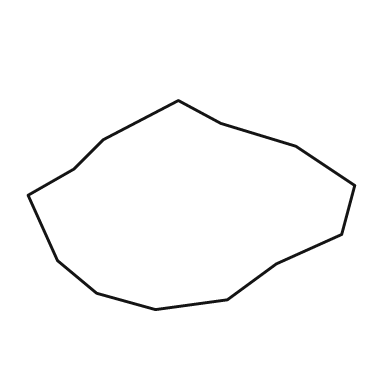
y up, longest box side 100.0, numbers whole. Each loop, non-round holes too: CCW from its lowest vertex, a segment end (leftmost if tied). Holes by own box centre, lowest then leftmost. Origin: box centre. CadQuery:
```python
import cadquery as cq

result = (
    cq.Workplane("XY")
    .moveTo(-11.0, -32.0)
    .lineTo(11.0, -29.0)
    .lineTo(26.0, -18.0)
    .lineTo(46.0, -9.0)
    .lineTo(50.0, 6.0)
    .lineTo(32.0, 18.0)
    .lineTo(9.0, 25.0)
    .lineTo(-4.0, 32.0)
    .lineTo(-27.0, 20.0)
    .lineTo(-36.0, 11.0)
    .lineTo(-50.0, 3.0)
    .lineTo(-41.0, -17.0)
    .lineTo(-29.0, -27.0)
    .close()
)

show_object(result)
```